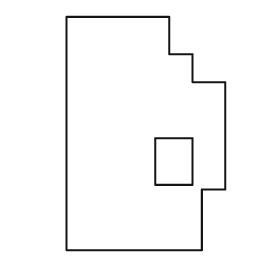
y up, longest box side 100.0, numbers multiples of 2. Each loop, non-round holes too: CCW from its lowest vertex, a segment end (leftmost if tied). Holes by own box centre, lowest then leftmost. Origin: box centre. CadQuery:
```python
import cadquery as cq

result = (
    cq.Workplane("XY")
    .moveTo(-34.0, -50.0)
    .lineTo(24.0, -50.0)
    .lineTo(24.0, -24.0)
    .lineTo(34.0, -24.0)
    .lineTo(34.0, 22.0)
    .lineTo(20.0, 22.0)
    .lineTo(20.0, 34.0)
    .lineTo(10.0, 34.0)
    .lineTo(10.0, 50.0)
    .lineTo(-34.0, 50.0)
    .close()
    .moveTo(4.0, -22.0)
    .lineTo(20.0, -22.0)
    .lineTo(20.0, -2.0)
    .lineTo(4.0, -2.0)
    .close()
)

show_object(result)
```